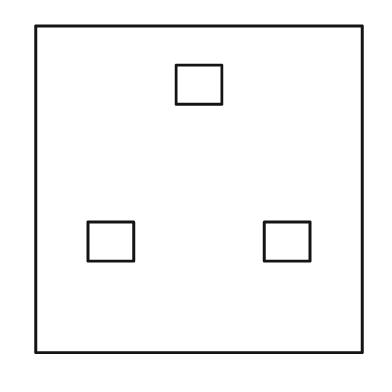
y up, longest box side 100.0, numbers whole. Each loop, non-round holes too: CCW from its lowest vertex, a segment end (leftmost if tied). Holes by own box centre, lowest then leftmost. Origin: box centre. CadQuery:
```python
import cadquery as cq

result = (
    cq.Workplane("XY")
    .moveTo(-50.0, -50.0)
    .lineTo(50.0, -50.0)
    .lineTo(50.0, 50.0)
    .lineTo(-50.0, 50.0)
    .close()
    .moveTo(-34.0, -22.0)
    .lineTo(-20.0, -22.0)
    .lineTo(-20.0, -10.0)
    .lineTo(-34.0, -10.0)
    .close()
    .moveTo(20.0, -22.0)
    .lineTo(34.0, -22.0)
    .lineTo(34.0, -10.0)
    .lineTo(20.0, -10.0)
    .close()
    .moveTo(-7.0, 26.0)
    .lineTo(7.0, 26.0)
    .lineTo(7.0, 38.0)
    .lineTo(-7.0, 38.0)
    .close()
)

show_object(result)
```